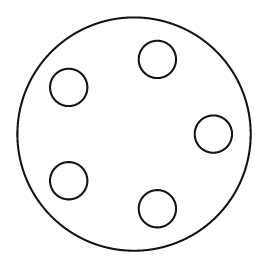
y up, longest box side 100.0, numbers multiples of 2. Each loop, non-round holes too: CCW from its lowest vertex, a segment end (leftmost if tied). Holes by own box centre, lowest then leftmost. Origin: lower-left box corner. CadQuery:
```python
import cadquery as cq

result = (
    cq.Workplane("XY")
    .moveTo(50.0, 50.0)
    .circle(50.0)
    .moveTo(60.0, 18.0)
    .circle(8.0)
    .moveTo(22.0, 30.0)
    .circle(8.0)
    .moveTo(84.0, 50.0)
    .circle(8.0)
    .moveTo(22.0, 70.0)
    .circle(8.0)
    .moveTo(60.0, 82.0)
    .circle(8.0)
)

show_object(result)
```